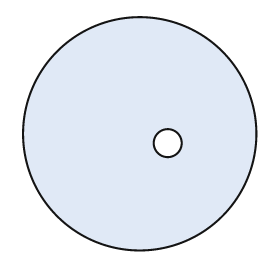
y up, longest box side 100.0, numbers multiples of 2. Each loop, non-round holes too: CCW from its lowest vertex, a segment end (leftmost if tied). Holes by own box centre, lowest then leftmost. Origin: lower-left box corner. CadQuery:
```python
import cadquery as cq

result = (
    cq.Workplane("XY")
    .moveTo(50.0, 50.0)
    .circle(50.0)
    .moveTo(62.0, 46.0)
    .circle(6.0)
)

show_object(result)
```